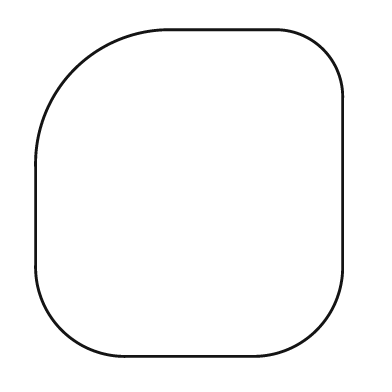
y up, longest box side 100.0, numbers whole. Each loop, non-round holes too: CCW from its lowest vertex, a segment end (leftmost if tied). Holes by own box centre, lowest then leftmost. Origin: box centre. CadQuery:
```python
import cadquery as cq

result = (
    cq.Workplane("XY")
    .moveTo(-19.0, -50.0)
    .lineTo(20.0, -50.0)
    .threePointArc((39.0, -42.0), (47.0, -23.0))
    .lineTo(47.0, 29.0)
    .threePointArc((41.0, 44.0), (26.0, 50.0))
    .lineTo(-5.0, 50.0)
    .threePointArc((-35.0, 38.0), (-47.0, 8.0))
    .lineTo(-47.0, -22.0)
    .threePointArc((-39.0, -42.0), (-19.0, -50.0))
    .close()
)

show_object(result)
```